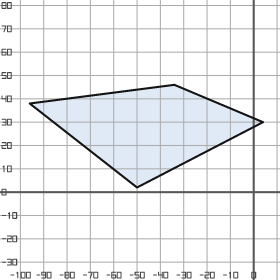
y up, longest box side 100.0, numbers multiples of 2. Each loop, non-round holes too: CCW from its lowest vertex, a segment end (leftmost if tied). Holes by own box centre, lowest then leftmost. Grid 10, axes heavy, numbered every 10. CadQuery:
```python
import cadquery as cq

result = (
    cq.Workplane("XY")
    .moveTo(-50.0, 2.0)
    .lineTo(4.0, 30.0)
    .lineTo(-34.0, 46.0)
    .lineTo(-96.0, 38.0)
    .close()
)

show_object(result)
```